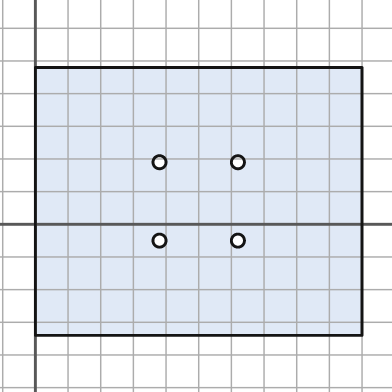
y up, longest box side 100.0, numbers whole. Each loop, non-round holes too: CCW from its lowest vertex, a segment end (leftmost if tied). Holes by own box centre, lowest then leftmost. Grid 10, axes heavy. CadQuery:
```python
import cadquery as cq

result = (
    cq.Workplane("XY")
    .moveTo(0.0, -34.0)
    .lineTo(100.0, -34.0)
    .lineTo(100.0, 48.0)
    .lineTo(0.0, 48.0)
    .close()
    .moveTo(38.0, -5.0)
    .circle(2.0)
    .moveTo(62.0, -5.0)
    .circle(2.0)
    .moveTo(38.0, 19.0)
    .circle(2.0)
    .moveTo(62.0, 19.0)
    .circle(2.0)
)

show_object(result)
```